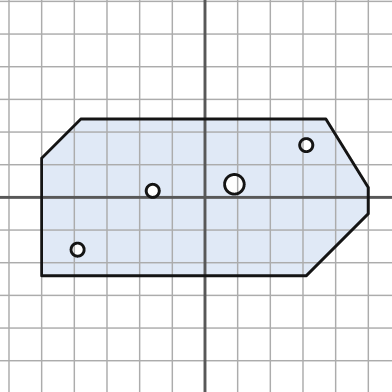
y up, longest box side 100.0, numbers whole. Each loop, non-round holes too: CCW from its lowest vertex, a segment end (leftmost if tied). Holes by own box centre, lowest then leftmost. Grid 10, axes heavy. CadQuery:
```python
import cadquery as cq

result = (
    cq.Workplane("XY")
    .moveTo(-50.0, -24.0)
    .lineTo(31.0, -24.0)
    .lineTo(50.0, -5.0)
    .lineTo(50.0, 3.0)
    .lineTo(37.0, 24.0)
    .lineTo(-38.0, 24.0)
    .lineTo(-50.0, 12.0)
    .close()
    .moveTo(-39.0, -16.0)
    .circle(2.0)
    .moveTo(-16.0, 2.0)
    .circle(2.0)
    .moveTo(9.0, 4.0)
    .circle(3.0)
    .moveTo(31.0, 16.0)
    .circle(2.0)
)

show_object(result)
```